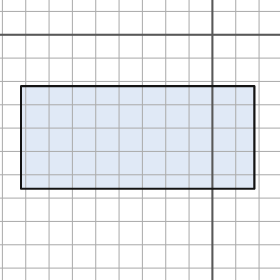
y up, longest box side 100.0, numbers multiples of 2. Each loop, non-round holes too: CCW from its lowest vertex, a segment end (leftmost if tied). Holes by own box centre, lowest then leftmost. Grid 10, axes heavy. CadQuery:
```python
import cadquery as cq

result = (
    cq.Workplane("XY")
    .moveTo(-82.0, -66.0)
    .lineTo(18.0, -66.0)
    .lineTo(18.0, -22.0)
    .lineTo(-82.0, -22.0)
    .close()
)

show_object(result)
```